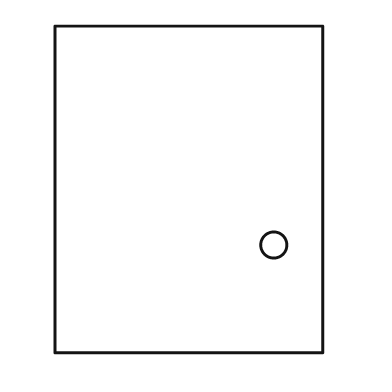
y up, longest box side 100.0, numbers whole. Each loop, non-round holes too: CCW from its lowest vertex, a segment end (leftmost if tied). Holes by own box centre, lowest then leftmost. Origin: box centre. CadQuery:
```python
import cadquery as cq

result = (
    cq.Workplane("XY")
    .moveTo(-41.0, -50.0)
    .lineTo(41.0, -50.0)
    .lineTo(41.0, 50.0)
    .lineTo(-41.0, 50.0)
    .close()
    .moveTo(26.0, -17.0)
    .circle(4.0)
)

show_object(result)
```